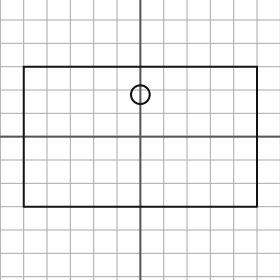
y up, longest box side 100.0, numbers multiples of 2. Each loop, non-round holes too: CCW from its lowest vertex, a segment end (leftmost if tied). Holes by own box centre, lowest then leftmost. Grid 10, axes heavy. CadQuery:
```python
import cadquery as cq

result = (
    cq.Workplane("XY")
    .moveTo(-50.0, -30.0)
    .lineTo(50.0, -30.0)
    .lineTo(50.0, 30.0)
    .lineTo(-50.0, 30.0)
    .close()
    .moveTo(0.0, 18.0)
    .circle(4.0)
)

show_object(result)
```